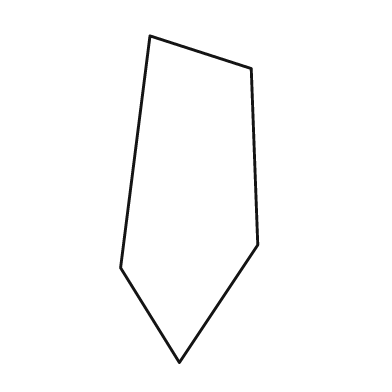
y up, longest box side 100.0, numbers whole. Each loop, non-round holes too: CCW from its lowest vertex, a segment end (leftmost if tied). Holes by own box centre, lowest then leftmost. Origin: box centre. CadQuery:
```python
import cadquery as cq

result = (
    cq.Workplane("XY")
    .moveTo(-3.0, -50.0)
    .lineTo(21.0, -14.0)
    .lineTo(19.0, 40.0)
    .lineTo(-12.0, 50.0)
    .lineTo(-21.0, -21.0)
    .close()
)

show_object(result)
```